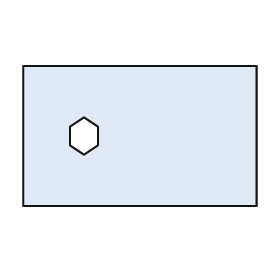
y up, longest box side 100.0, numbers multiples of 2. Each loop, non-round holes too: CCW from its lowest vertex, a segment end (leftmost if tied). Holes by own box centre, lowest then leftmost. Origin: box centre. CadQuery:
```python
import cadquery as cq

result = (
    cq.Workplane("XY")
    .moveTo(-50.0, -30.0)
    .lineTo(50.0, -30.0)
    .lineTo(50.0, 30.0)
    .lineTo(-50.0, 30.0)
    .close()
    .moveTo(-24.0, -8.0)
    .lineTo(-18.0, -4.0)
    .lineTo(-18.0, 4.0)
    .lineTo(-24.0, 8.0)
    .lineTo(-30.0, 4.0)
    .lineTo(-30.0, -4.0)
    .close()
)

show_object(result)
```